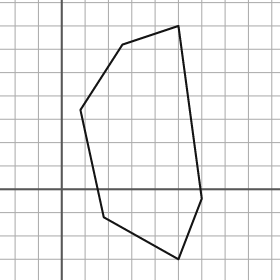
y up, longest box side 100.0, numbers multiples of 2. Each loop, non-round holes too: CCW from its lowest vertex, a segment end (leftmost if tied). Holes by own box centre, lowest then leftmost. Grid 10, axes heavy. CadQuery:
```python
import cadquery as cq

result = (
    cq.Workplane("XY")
    .moveTo(50.0, -30.0)
    .lineTo(60.0, -4.0)
    .lineTo(50.0, 70.0)
    .lineTo(26.0, 62.0)
    .lineTo(8.0, 34.0)
    .lineTo(18.0, -12.0)
    .close()
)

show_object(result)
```